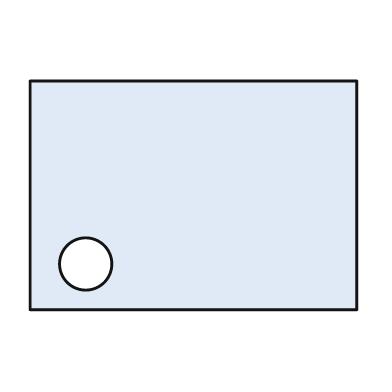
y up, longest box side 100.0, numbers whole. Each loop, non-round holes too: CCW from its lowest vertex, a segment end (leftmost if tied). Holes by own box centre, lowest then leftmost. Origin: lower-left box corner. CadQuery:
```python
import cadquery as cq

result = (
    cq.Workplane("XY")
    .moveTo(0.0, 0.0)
    .lineTo(100.0, 0.0)
    .lineTo(100.0, 70.0)
    .lineTo(0.0, 70.0)
    .close()
    .moveTo(17.0, 14.0)
    .circle(8.0)
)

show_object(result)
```